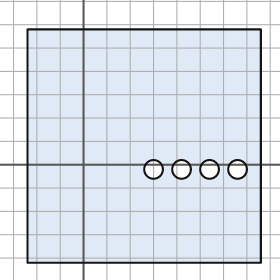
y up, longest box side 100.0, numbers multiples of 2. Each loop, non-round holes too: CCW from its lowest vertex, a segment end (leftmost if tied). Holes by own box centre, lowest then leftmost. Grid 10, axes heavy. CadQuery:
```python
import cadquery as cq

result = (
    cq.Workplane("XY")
    .moveTo(-24.0, -42.0)
    .lineTo(76.0, -42.0)
    .lineTo(76.0, 58.0)
    .lineTo(-24.0, 58.0)
    .close()
    .moveTo(30.0, -2.0)
    .circle(4.0)
    .moveTo(42.0, -2.0)
    .circle(4.0)
    .moveTo(54.0, -2.0)
    .circle(4.0)
    .moveTo(66.0, -2.0)
    .circle(4.0)
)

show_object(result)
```